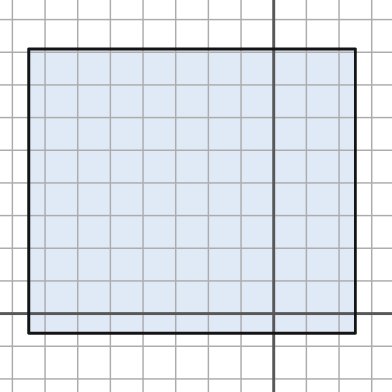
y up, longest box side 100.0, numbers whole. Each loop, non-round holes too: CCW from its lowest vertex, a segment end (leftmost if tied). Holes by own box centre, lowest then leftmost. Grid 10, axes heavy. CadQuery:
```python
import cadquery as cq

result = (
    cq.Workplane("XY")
    .moveTo(-75.0, -6.0)
    .lineTo(25.0, -6.0)
    .lineTo(25.0, 81.0)
    .lineTo(-75.0, 81.0)
    .close()
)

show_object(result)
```